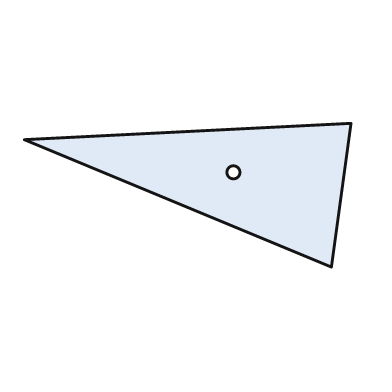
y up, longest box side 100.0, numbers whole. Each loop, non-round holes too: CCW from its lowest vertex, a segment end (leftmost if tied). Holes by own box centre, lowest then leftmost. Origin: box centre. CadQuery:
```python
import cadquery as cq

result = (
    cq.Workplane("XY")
    .moveTo(44.0, -22.0)
    .lineTo(50.0, 22.0)
    .lineTo(-50.0, 17.0)
    .close()
    .moveTo(14.0, 7.0)
    .circle(2.0)
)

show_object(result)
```